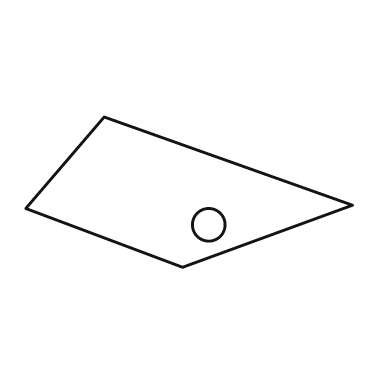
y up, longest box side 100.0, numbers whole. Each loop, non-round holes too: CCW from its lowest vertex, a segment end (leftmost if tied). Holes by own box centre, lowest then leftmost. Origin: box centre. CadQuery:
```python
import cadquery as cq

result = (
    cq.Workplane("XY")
    .moveTo(-2.0, -23.0)
    .lineTo(50.0, -4.0)
    .lineTo(-26.0, 23.0)
    .lineTo(-50.0, -5.0)
    .close()
    .moveTo(6.0, -10.0)
    .circle(5.0)
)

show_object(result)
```